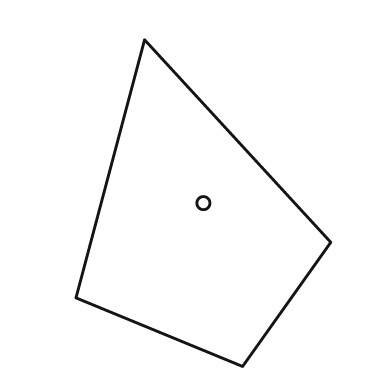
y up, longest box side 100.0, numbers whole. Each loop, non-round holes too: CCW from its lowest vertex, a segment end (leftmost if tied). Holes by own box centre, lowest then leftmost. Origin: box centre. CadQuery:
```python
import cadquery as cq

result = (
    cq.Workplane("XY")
    .moveTo(12.0, -50.0)
    .lineTo(39.0, -12.0)
    .lineTo(-18.0, 50.0)
    .lineTo(-39.0, -29.0)
    .close()
    .moveTo(0.0, 0.0)
    .circle(2.0)
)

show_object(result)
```